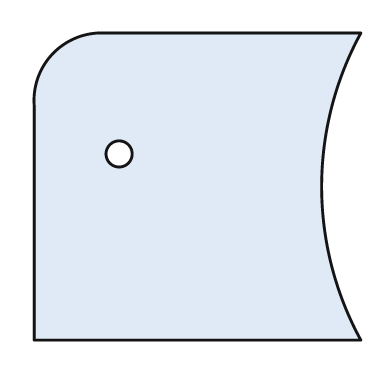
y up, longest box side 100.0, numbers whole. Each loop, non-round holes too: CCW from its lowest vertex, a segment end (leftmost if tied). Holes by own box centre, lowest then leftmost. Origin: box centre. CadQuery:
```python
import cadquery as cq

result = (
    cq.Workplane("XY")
    .moveTo(-50.0, -47.0)
    .lineTo(50.0, -47.0)
    .threePointArc((38.0, 0.0), (50.0, 47.0))
    .lineTo(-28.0, 47.0)
    .threePointArc((-44.0, 41.0), (-50.0, 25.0))
    .close()
    .moveTo(-24.0, 10.0)
    .circle(4.0)
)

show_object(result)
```